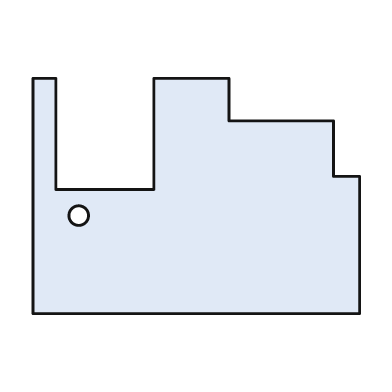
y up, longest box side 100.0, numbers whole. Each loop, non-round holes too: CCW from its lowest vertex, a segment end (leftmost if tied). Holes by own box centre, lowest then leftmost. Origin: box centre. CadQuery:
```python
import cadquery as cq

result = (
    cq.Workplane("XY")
    .moveTo(-50.0, -36.0)
    .lineTo(50.0, -36.0)
    .lineTo(50.0, 6.0)
    .lineTo(42.0, 6.0)
    .lineTo(42.0, 23.0)
    .lineTo(10.0, 23.0)
    .lineTo(10.0, 36.0)
    .lineTo(-13.0, 36.0)
    .lineTo(-13.0, 2.0)
    .lineTo(-43.0, 2.0)
    .lineTo(-43.0, 36.0)
    .lineTo(-50.0, 36.0)
    .close()
    .moveTo(-36.0, -6.0)
    .circle(3.0)
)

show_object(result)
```